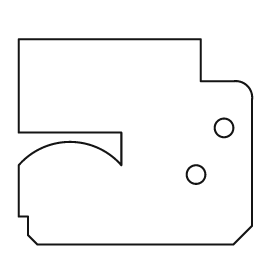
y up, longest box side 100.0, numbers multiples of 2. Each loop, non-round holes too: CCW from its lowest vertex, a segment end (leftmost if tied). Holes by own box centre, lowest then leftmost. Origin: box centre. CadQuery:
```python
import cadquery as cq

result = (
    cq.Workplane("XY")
    .moveTo(-42.0, -44.0)
    .lineTo(42.0, -44.0)
    .lineTo(50.0, -36.0)
    .lineTo(50.0, 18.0)
    .threePointArc((48.0, 24.0), (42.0, 26.0))
    .lineTo(28.0, 26.0)
    .lineTo(28.0, 44.0)
    .lineTo(-50.0, 44.0)
    .lineTo(-50.0, 4.0)
    .lineTo(-6.0, 4.0)
    .lineTo(-6.0, -10.0)
    .threePointArc((-28.0, 0.0), (-50.0, -10.0))
    .lineTo(-50.0, -32.0)
    .lineTo(-46.0, -32.0)
    .lineTo(-46.0, -40.0)
    .close()
    .moveTo(26.0, -14.0)
    .circle(4.0)
    .moveTo(38.0, 6.0)
    .circle(4.0)
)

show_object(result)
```